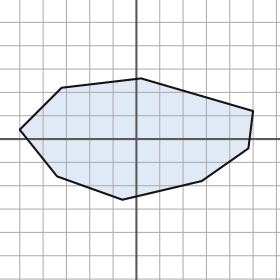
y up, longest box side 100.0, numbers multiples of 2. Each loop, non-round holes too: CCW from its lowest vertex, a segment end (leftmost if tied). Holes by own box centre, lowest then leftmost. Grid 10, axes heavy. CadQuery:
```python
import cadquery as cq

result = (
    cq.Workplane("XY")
    .moveTo(-6.0, -26.0)
    .lineTo(28.0, -18.0)
    .lineTo(48.0, -4.0)
    .lineTo(50.0, 12.0)
    .lineTo(2.0, 26.0)
    .lineTo(-32.0, 22.0)
    .lineTo(-50.0, 4.0)
    .lineTo(-34.0, -16.0)
    .close()
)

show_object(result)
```